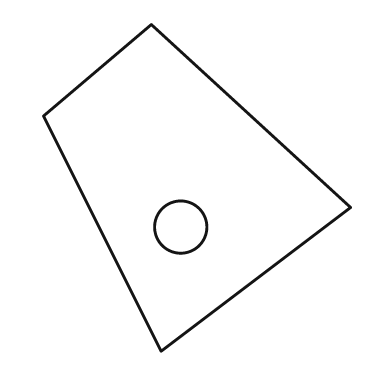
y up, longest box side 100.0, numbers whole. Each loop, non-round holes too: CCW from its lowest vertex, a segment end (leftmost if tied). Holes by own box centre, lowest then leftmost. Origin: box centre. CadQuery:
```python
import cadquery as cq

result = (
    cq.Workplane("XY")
    .moveTo(-11.0, -50.0)
    .lineTo(47.0, -6.0)
    .lineTo(-14.0, 50.0)
    .lineTo(-47.0, 22.0)
    .close()
    .moveTo(-5.0, -12.0)
    .circle(8.0)
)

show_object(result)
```